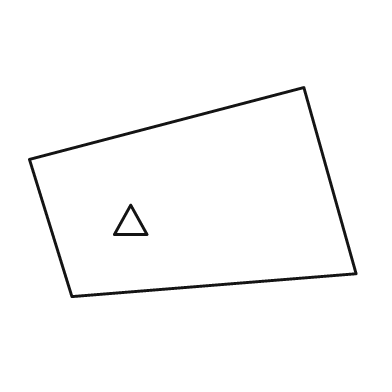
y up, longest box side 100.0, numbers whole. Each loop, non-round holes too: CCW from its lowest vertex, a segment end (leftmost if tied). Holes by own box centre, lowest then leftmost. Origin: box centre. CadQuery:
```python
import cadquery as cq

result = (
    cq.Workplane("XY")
    .moveTo(-37.0, -32.0)
    .lineTo(50.0, -25.0)
    .lineTo(34.0, 32.0)
    .lineTo(-50.0, 10.0)
    .close()
    .moveTo(-24.0, -13.0)
    .lineTo(-14.0, -13.0)
    .lineTo(-19.0, -4.0)
    .close()
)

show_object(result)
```